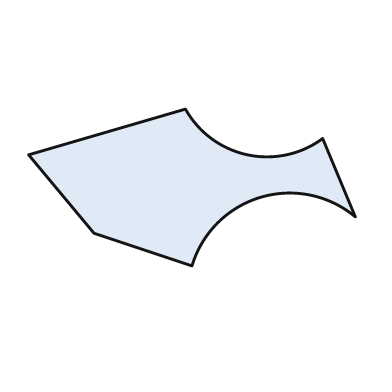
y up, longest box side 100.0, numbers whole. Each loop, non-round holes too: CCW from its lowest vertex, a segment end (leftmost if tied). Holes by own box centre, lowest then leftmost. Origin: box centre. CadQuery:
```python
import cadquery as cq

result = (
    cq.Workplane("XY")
    .moveTo(0.0, -24.0)
    .threePointArc((21.0, -3.0), (50.0, -9.0))
    .lineTo(40.0, 15.0)
    .threePointArc((17.0, 10.0), (-2.0, 24.0))
    .lineTo(-50.0, 10.0)
    .lineTo(-30.0, -14.0)
    .close()
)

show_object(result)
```